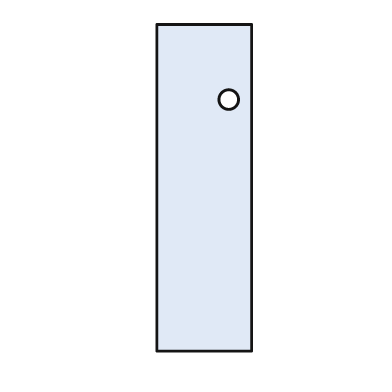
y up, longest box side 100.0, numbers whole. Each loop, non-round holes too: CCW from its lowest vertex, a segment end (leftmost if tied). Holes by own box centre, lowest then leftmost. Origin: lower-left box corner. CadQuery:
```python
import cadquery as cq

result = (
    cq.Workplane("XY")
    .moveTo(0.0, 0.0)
    .lineTo(29.0, 0.0)
    .lineTo(29.0, 100.0)
    .lineTo(0.0, 100.0)
    .close()
    .moveTo(22.0, 77.0)
    .circle(3.0)
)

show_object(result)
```